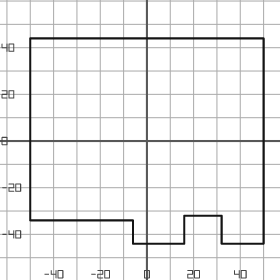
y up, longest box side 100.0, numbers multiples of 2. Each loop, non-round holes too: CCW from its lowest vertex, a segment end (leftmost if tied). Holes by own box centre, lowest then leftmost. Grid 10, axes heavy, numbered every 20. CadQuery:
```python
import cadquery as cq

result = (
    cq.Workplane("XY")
    .moveTo(-6.0, -44.0)
    .lineTo(16.0, -44.0)
    .lineTo(16.0, -32.0)
    .lineTo(32.0, -32.0)
    .lineTo(32.0, -44.0)
    .lineTo(50.0, -44.0)
    .lineTo(50.0, 44.0)
    .lineTo(-50.0, 44.0)
    .lineTo(-50.0, -34.0)
    .lineTo(-6.0, -34.0)
    .close()
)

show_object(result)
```